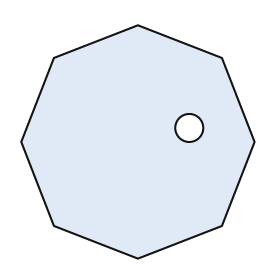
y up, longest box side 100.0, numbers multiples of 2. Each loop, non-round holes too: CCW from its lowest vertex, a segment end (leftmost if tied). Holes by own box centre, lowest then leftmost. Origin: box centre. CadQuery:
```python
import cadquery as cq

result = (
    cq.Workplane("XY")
    .moveTo(0.0, -50.0)
    .lineTo(36.0, -36.0)
    .lineTo(50.0, 0.0)
    .lineTo(36.0, 36.0)
    .lineTo(0.0, 50.0)
    .lineTo(-36.0, 36.0)
    .lineTo(-50.0, 0.0)
    .lineTo(-36.0, -36.0)
    .close()
    .moveTo(22.0, 6.0)
    .circle(6.0)
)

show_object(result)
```